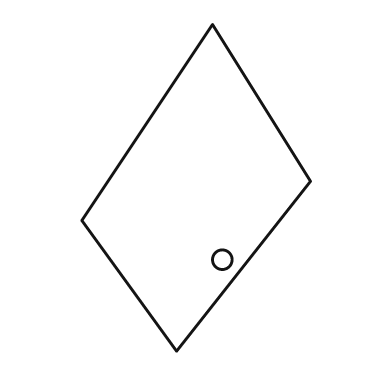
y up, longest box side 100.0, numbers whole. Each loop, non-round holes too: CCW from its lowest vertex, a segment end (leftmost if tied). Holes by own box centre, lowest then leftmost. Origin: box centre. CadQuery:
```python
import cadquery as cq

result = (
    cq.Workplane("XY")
    .moveTo(-6.0, -50.0)
    .lineTo(35.0, 2.0)
    .lineTo(5.0, 50.0)
    .lineTo(-35.0, -10.0)
    .close()
    .moveTo(8.0, -22.0)
    .circle(3.0)
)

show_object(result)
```